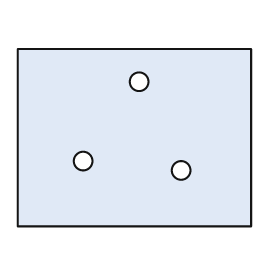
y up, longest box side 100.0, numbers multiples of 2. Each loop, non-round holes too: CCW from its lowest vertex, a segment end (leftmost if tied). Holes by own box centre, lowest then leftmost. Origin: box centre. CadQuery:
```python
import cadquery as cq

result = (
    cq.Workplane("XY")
    .moveTo(-50.0, -38.0)
    .lineTo(50.0, -38.0)
    .lineTo(50.0, 38.0)
    .lineTo(-50.0, 38.0)
    .close()
    .moveTo(20.0, -14.0)
    .circle(4.0)
    .moveTo(-22.0, -10.0)
    .circle(4.0)
    .moveTo(2.0, 24.0)
    .circle(4.0)
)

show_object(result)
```